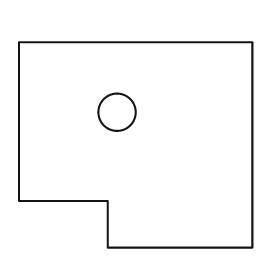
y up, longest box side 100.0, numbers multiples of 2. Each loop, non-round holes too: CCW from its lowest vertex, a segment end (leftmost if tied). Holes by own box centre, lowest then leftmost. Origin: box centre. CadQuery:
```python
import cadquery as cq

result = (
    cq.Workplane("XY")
    .moveTo(-12.0, -44.0)
    .lineTo(50.0, -44.0)
    .lineTo(50.0, 44.0)
    .lineTo(-50.0, 44.0)
    .lineTo(-50.0, -24.0)
    .lineTo(-12.0, -24.0)
    .close()
    .moveTo(-8.0, 14.0)
    .circle(8.0)
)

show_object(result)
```